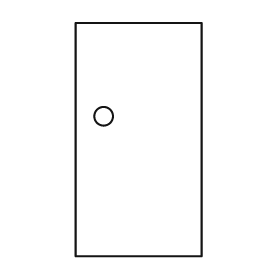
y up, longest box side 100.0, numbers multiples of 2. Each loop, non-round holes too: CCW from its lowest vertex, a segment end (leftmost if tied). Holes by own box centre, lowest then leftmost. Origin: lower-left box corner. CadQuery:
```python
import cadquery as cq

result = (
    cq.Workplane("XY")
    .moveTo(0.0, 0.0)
    .lineTo(54.0, 0.0)
    .lineTo(54.0, 100.0)
    .lineTo(0.0, 100.0)
    .close()
    .moveTo(12.0, 60.0)
    .circle(4.0)
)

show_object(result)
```